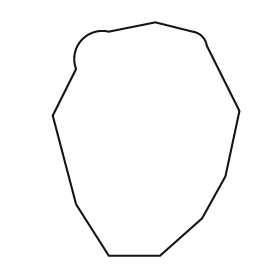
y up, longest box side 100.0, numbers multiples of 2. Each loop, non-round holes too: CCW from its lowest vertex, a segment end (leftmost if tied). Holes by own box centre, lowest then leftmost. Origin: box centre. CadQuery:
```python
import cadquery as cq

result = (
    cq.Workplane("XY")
    .moveTo(-16.0, -50.0)
    .lineTo(6.0, -50.0)
    .lineTo(24.0, -34.0)
    .lineTo(34.0, -16.0)
    .lineTo(40.0, 12.0)
    .lineTo(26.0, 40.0)
    .threePointArc((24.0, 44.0), (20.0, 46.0))
    .lineTo(4.0, 50.0)
    .lineTo(-16.0, 46.0)
    .threePointArc((-28.0, 42.0), (-30.0, 30.0))
    .lineTo(-40.0, 10.0)
    .lineTo(-30.0, -28.0)
    .close()
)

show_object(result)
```